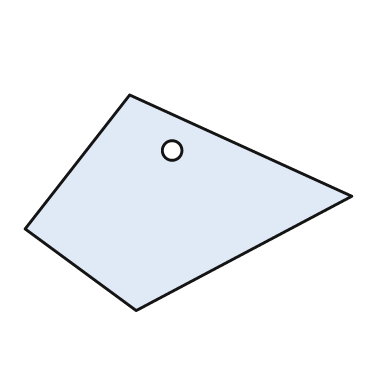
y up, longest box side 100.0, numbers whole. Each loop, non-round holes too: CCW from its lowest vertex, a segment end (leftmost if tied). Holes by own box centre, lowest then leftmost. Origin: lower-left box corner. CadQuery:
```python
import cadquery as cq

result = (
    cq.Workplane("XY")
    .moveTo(34.0, 0.0)
    .lineTo(100.0, 35.0)
    .lineTo(32.0, 66.0)
    .lineTo(0.0, 25.0)
    .close()
    .moveTo(45.0, 49.0)
    .circle(3.0)
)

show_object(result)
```